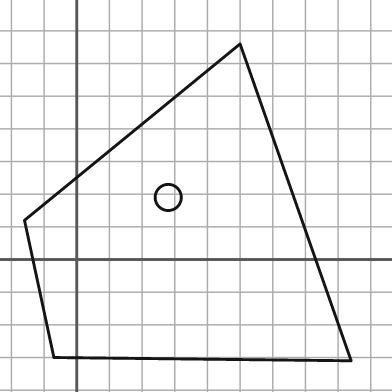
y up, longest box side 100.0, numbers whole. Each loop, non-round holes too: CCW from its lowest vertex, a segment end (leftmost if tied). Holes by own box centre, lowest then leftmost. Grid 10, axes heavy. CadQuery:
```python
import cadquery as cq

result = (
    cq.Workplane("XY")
    .moveTo(84.0, -31.0)
    .lineTo(50.0, 66.0)
    .lineTo(-16.0, 12.0)
    .lineTo(-7.0, -30.0)
    .close()
    .moveTo(28.0, 19.0)
    .circle(4.0)
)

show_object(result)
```